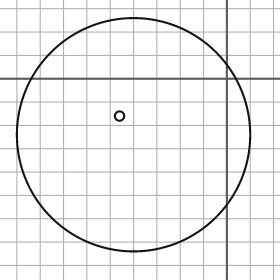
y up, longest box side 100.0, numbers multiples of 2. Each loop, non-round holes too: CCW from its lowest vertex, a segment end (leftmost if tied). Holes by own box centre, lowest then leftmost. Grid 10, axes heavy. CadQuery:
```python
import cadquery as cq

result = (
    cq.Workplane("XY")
    .moveTo(-40.0, -24.0)
    .circle(50.0)
    .moveTo(-46.0, -16.0)
    .circle(2.0)
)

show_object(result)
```